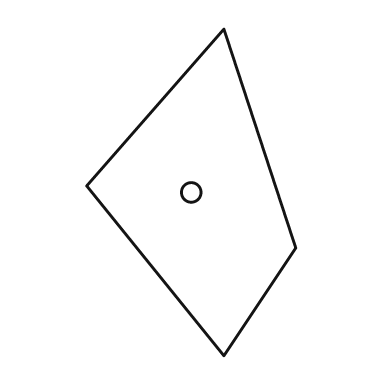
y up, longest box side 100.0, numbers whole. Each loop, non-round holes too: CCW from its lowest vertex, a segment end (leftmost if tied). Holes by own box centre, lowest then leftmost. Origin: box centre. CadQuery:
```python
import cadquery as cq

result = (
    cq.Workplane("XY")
    .moveTo(10.0, -50.0)
    .lineTo(32.0, -17.0)
    .lineTo(10.0, 50.0)
    .lineTo(-32.0, 2.0)
    .close()
    .moveTo(0.0, 0.0)
    .circle(3.0)
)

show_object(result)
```